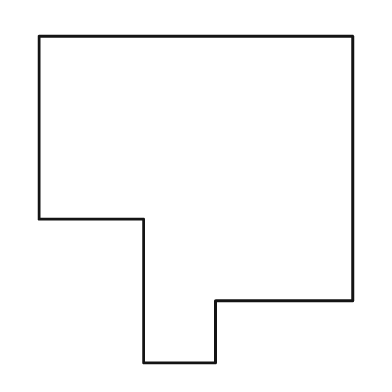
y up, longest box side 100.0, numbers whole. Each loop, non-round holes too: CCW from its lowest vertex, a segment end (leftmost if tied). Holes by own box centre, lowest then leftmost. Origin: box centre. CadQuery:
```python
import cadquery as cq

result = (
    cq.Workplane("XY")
    .moveTo(-16.0, -50.0)
    .lineTo(6.0, -50.0)
    .lineTo(6.0, -31.0)
    .lineTo(48.0, -31.0)
    .lineTo(48.0, 50.0)
    .lineTo(-48.0, 50.0)
    .lineTo(-48.0, -6.0)
    .lineTo(-16.0, -6.0)
    .close()
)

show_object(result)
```